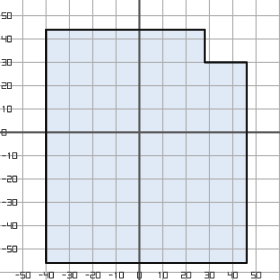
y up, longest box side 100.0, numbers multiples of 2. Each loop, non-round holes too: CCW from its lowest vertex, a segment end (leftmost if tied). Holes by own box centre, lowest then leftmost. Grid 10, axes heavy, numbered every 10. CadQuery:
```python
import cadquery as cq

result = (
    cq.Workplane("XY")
    .moveTo(-40.0, -56.0)
    .lineTo(46.0, -56.0)
    .lineTo(46.0, 30.0)
    .lineTo(28.0, 30.0)
    .lineTo(28.0, 44.0)
    .lineTo(-40.0, 44.0)
    .close()
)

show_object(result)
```